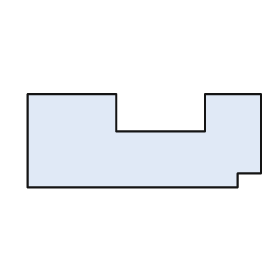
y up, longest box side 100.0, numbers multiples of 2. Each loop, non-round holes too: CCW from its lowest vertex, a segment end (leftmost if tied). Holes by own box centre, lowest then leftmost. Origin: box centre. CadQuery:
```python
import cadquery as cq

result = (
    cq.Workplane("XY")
    .moveTo(-50.0, -20.0)
    .lineTo(40.0, -20.0)
    .lineTo(40.0, -14.0)
    .lineTo(50.0, -14.0)
    .lineTo(50.0, 20.0)
    .lineTo(26.0, 20.0)
    .lineTo(26.0, 4.0)
    .lineTo(-12.0, 4.0)
    .lineTo(-12.0, 20.0)
    .lineTo(-50.0, 20.0)
    .close()
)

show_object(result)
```